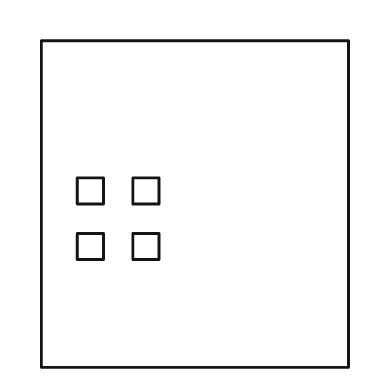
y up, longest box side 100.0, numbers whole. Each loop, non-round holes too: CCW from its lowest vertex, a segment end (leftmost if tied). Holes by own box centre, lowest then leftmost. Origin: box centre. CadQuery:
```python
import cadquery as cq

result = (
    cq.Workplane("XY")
    .moveTo(-47.0, -50.0)
    .lineTo(47.0, -50.0)
    .lineTo(47.0, 50.0)
    .lineTo(-47.0, 50.0)
    .close()
    .moveTo(-36.0, -17.0)
    .lineTo(-28.0, -17.0)
    .lineTo(-28.0, -9.0)
    .lineTo(-36.0, -9.0)
    .close()
    .moveTo(-19.0, -17.0)
    .lineTo(-11.0, -17.0)
    .lineTo(-11.0, -9.0)
    .lineTo(-19.0, -9.0)
    .close()
    .moveTo(-36.0, 0.0)
    .lineTo(-28.0, 0.0)
    .lineTo(-28.0, 8.0)
    .lineTo(-36.0, 8.0)
    .close()
    .moveTo(-19.0, 0.0)
    .lineTo(-11.0, 0.0)
    .lineTo(-11.0, 8.0)
    .lineTo(-19.0, 8.0)
    .close()
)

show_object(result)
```